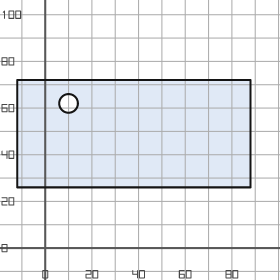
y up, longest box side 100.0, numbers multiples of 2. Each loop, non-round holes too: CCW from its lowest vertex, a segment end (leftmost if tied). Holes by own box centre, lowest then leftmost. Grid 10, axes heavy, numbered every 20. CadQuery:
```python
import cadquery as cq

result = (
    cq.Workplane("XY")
    .moveTo(-12.0, 26.0)
    .lineTo(88.0, 26.0)
    .lineTo(88.0, 72.0)
    .lineTo(-12.0, 72.0)
    .close()
    .moveTo(10.0, 62.0)
    .circle(4.0)
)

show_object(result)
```